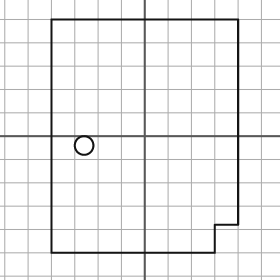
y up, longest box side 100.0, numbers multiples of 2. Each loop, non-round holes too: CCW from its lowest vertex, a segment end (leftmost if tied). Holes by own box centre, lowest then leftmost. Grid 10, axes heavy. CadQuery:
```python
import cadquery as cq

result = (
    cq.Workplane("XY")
    .moveTo(-40.0, -50.0)
    .lineTo(30.0, -50.0)
    .lineTo(30.0, -38.0)
    .lineTo(40.0, -38.0)
    .lineTo(40.0, 50.0)
    .lineTo(-40.0, 50.0)
    .close()
    .moveTo(-26.0, -4.0)
    .circle(4.0)
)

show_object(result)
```